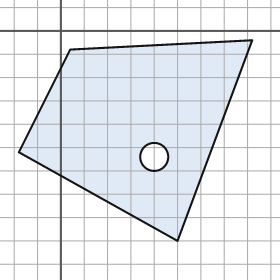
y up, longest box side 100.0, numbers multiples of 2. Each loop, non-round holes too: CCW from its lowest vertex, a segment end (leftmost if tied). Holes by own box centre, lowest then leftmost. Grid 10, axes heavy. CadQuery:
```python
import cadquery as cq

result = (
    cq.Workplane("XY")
    .moveTo(50.0, -90.0)
    .lineTo(82.0, -4.0)
    .lineTo(4.0, -8.0)
    .lineTo(-18.0, -52.0)
    .close()
    .moveTo(40.0, -54.0)
    .circle(6.0)
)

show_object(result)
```